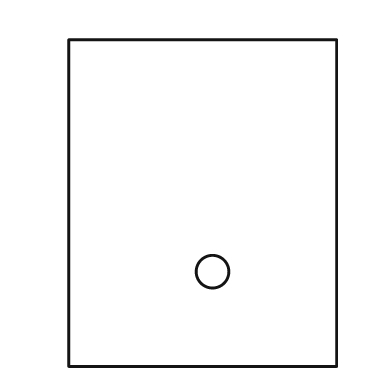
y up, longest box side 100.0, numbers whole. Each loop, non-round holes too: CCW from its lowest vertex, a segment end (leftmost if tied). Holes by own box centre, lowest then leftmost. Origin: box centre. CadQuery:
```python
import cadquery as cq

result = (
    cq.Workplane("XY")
    .moveTo(-41.0, -50.0)
    .lineTo(41.0, -50.0)
    .lineTo(41.0, 50.0)
    .lineTo(-41.0, 50.0)
    .close()
    .moveTo(3.0, -21.0)
    .circle(5.0)
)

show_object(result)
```